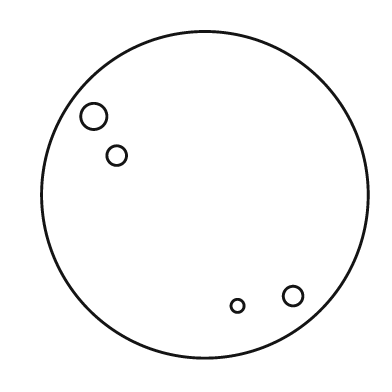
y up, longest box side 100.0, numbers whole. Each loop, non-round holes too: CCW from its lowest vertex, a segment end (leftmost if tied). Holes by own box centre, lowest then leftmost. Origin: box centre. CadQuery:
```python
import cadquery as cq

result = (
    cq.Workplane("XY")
    .moveTo(0.0, 0.0)
    .circle(50.0)
    .moveTo(10.0, -34.0)
    .circle(2.0)
    .moveTo(27.0, -31.0)
    .circle(3.0)
    .moveTo(-27.0, 12.0)
    .circle(3.0)
    .moveTo(-34.0, 24.0)
    .circle(4.0)
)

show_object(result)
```